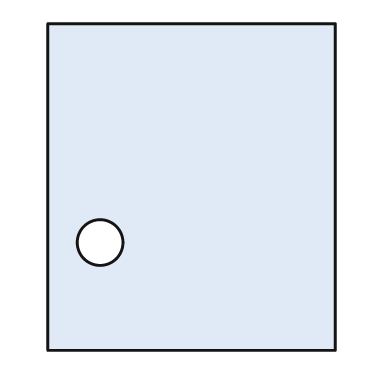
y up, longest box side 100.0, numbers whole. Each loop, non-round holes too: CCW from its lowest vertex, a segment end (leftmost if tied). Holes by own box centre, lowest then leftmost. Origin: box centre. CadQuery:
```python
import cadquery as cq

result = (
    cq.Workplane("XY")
    .moveTo(-44.0, -50.0)
    .lineTo(44.0, -50.0)
    .lineTo(44.0, 50.0)
    .lineTo(-44.0, 50.0)
    .close()
    .moveTo(-28.0, -17.0)
    .circle(7.0)
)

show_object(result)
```